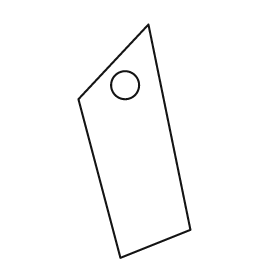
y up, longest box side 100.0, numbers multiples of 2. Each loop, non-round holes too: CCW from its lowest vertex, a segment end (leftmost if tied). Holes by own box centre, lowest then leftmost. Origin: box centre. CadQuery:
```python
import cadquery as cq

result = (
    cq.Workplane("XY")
    .moveTo(-6.0, -50.0)
    .lineTo(24.0, -38.0)
    .lineTo(6.0, 50.0)
    .lineTo(-24.0, 18.0)
    .close()
    .moveTo(-4.0, 24.0)
    .circle(6.0)
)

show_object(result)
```